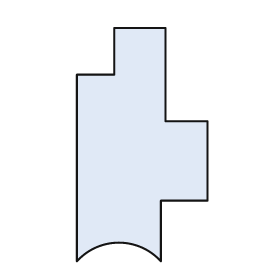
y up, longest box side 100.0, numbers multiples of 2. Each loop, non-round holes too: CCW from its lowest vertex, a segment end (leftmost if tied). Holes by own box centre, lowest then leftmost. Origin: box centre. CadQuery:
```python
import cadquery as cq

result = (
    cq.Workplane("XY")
    .moveTo(-28.0, -50.0)
    .threePointArc((-10.0, -42.0), (8.0, -50.0))
    .lineTo(8.0, -24.0)
    .lineTo(28.0, -24.0)
    .lineTo(28.0, 10.0)
    .lineTo(10.0, 10.0)
    .lineTo(10.0, 50.0)
    .lineTo(-12.0, 50.0)
    .lineTo(-12.0, 30.0)
    .lineTo(-28.0, 30.0)
    .close()
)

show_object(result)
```